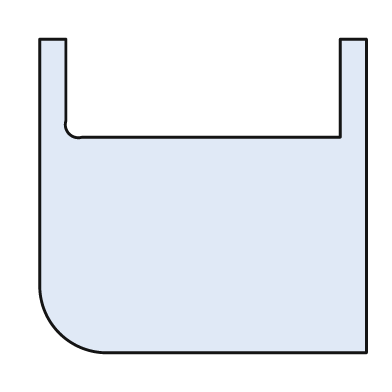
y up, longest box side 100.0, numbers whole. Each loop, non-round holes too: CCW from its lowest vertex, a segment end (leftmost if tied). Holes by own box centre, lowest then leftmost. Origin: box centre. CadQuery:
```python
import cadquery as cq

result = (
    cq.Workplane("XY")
    .moveTo(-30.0, -48.0)
    .lineTo(50.0, -48.0)
    .lineTo(50.0, 48.0)
    .lineTo(42.0, 48.0)
    .lineTo(42.0, 18.0)
    .lineTo(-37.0, 18.0)
    .threePointArc((-41.0, 19.0), (-42.0, 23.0))
    .lineTo(-42.0, 48.0)
    .lineTo(-50.0, 48.0)
    .lineTo(-50.0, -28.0)
    .threePointArc((-44.0, -42.0), (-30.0, -48.0))
    .close()
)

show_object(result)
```